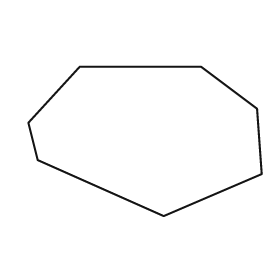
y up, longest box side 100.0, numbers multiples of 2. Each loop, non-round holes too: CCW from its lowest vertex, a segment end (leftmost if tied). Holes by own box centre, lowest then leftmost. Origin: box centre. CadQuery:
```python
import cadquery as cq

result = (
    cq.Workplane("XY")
    .moveTo(8.0, -32.0)
    .lineTo(50.0, -14.0)
    .lineTo(48.0, 14.0)
    .lineTo(24.0, 32.0)
    .lineTo(-28.0, 32.0)
    .lineTo(-50.0, 8.0)
    .lineTo(-46.0, -8.0)
    .close()
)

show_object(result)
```